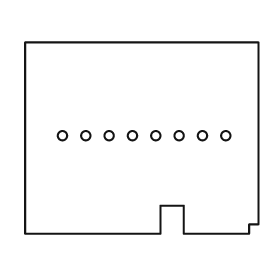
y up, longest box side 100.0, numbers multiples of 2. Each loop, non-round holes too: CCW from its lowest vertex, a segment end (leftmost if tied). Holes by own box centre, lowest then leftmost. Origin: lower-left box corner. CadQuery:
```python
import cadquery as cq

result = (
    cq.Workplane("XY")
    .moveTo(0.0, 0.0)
    .lineTo(58.0, 0.0)
    .lineTo(58.0, 12.0)
    .lineTo(68.0, 12.0)
    .lineTo(68.0, 0.0)
    .lineTo(96.0, 0.0)
    .lineTo(96.0, 4.0)
    .lineTo(100.0, 4.0)
    .lineTo(100.0, 82.0)
    .lineTo(0.0, 82.0)
    .close()
    .moveTo(16.0, 42.0)
    .circle(2.0)
    .moveTo(26.0, 42.0)
    .circle(2.0)
    .moveTo(36.0, 42.0)
    .circle(2.0)
    .moveTo(46.0, 42.0)
    .circle(2.0)
    .moveTo(56.0, 42.0)
    .circle(2.0)
    .moveTo(66.0, 42.0)
    .circle(2.0)
    .moveTo(76.0, 42.0)
    .circle(2.0)
    .moveTo(86.0, 42.0)
    .circle(2.0)
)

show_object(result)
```